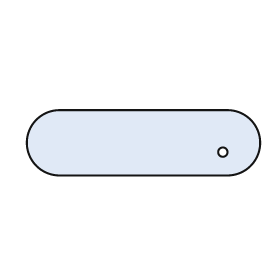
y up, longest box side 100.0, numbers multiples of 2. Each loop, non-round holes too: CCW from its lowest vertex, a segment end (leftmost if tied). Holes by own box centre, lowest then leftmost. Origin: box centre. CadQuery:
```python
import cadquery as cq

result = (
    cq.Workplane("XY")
    .moveTo(-36.0, -14.0)
    .lineTo(36.0, -14.0)
    .threePointArc((50.0, 0.0), (36.0, 14.0))
    .lineTo(-36.0, 14.0)
    .threePointArc((-50.0, 0.0), (-36.0, -14.0))
    .close()
    .moveTo(34.0, -4.0)
    .circle(2.0)
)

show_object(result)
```